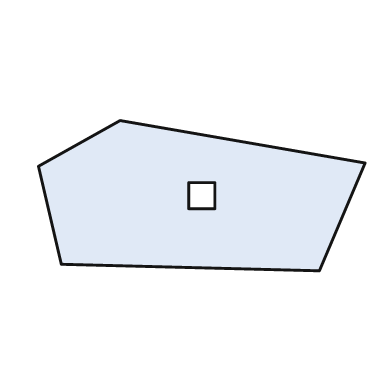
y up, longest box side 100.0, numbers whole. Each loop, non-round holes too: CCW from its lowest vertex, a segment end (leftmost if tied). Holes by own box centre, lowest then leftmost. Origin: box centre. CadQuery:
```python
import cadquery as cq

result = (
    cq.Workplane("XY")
    .moveTo(36.0, -23.0)
    .lineTo(50.0, 10.0)
    .lineTo(-25.0, 23.0)
    .lineTo(-50.0, 9.0)
    .lineTo(-43.0, -21.0)
    .close()
    .moveTo(-4.0, -4.0)
    .lineTo(4.0, -4.0)
    .lineTo(4.0, 4.0)
    .lineTo(-4.0, 4.0)
    .close()
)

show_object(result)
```